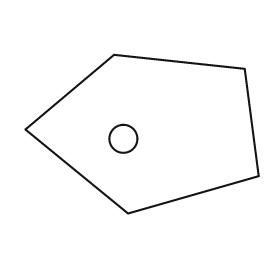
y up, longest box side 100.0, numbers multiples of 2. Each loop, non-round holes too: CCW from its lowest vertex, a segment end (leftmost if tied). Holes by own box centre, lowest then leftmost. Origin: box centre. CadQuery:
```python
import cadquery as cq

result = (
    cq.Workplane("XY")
    .moveTo(-6.0, -34.0)
    .lineTo(50.0, -18.0)
    .lineTo(44.0, 28.0)
    .lineTo(-12.0, 34.0)
    .lineTo(-50.0, 2.0)
    .close()
    .moveTo(-8.0, -2.0)
    .circle(6.0)
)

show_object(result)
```